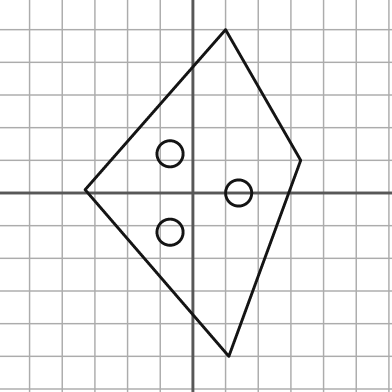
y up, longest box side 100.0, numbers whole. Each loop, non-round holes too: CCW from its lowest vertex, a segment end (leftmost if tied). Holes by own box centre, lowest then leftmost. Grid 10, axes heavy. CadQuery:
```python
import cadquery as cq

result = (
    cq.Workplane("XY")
    .moveTo(11.0, -50.0)
    .lineTo(33.0, 10.0)
    .lineTo(10.0, 50.0)
    .lineTo(-33.0, 1.0)
    .close()
    .moveTo(-7.0, -12.0)
    .circle(4.0)
    .moveTo(14.0, 0.0)
    .circle(4.0)
    .moveTo(-7.0, 12.0)
    .circle(4.0)
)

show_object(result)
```